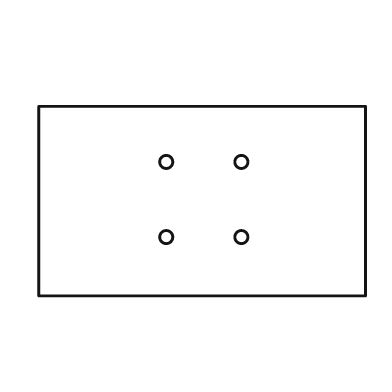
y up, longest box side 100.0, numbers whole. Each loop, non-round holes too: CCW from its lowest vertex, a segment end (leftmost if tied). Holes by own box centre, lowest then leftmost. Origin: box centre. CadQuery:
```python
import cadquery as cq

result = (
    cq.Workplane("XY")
    .moveTo(-50.0, -29.0)
    .lineTo(50.0, -29.0)
    .lineTo(50.0, 29.0)
    .lineTo(-50.0, 29.0)
    .close()
    .moveTo(-11.0, -11.0)
    .circle(2.0)
    .moveTo(12.0, -11.0)
    .circle(2.0)
    .moveTo(-11.0, 12.0)
    .circle(2.0)
    .moveTo(12.0, 12.0)
    .circle(2.0)
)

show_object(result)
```